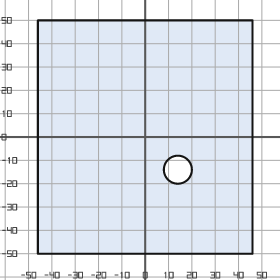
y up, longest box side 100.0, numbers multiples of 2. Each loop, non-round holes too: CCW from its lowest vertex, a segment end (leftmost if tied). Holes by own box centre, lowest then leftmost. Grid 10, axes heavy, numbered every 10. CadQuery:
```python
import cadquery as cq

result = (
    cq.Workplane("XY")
    .moveTo(-46.0, -50.0)
    .lineTo(46.0, -50.0)
    .lineTo(46.0, 50.0)
    .lineTo(-46.0, 50.0)
    .close()
    .moveTo(14.0, -14.0)
    .circle(6.0)
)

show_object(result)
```